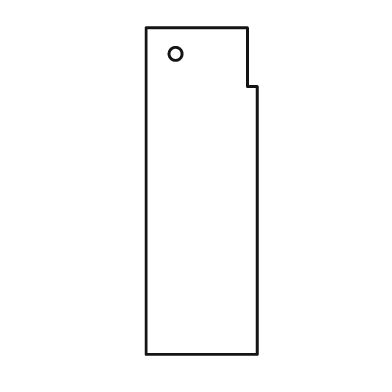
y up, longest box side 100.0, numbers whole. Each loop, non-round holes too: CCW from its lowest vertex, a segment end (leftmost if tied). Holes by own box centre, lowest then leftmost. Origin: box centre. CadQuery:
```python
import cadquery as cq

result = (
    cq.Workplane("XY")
    .moveTo(-17.0, -50.0)
    .lineTo(17.0, -50.0)
    .lineTo(17.0, 32.0)
    .lineTo(14.0, 32.0)
    .lineTo(14.0, 50.0)
    .lineTo(-17.0, 50.0)
    .close()
    .moveTo(-8.0, 42.0)
    .circle(2.0)
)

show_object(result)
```